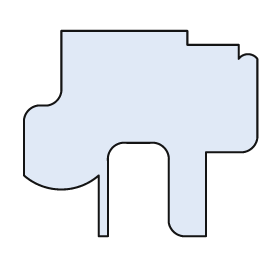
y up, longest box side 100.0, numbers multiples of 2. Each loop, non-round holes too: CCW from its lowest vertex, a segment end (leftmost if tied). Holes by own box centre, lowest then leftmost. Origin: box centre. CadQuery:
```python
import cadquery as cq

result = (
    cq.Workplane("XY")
    .moveTo(-18.0, -44.0)
    .lineTo(-14.0, -44.0)
    .lineTo(-14.0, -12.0)
    .threePointArc((-12.0, -6.0), (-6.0, -4.0))
    .lineTo(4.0, -4.0)
    .threePointArc((10.0, -6.0), (12.0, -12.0))
    .lineTo(12.0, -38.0)
    .threePointArc((14.0, -42.0), (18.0, -44.0))
    .lineTo(28.0, -44.0)
    .lineTo(28.0, -8.0)
    .lineTo(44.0, -8.0)
    .threePointArc((48.0, -6.0), (50.0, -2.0))
    .lineTo(50.0, 32.0)
    .threePointArc((46.0, 34.0), (42.0, 32.0))
    .lineTo(42.0, 38.0)
    .lineTo(20.0, 38.0)
    .lineTo(20.0, 44.0)
    .lineTo(-34.0, 44.0)
    .lineTo(-34.0, 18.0)
    .threePointArc((-36.0, 14.0), (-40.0, 12.0))
    .lineTo(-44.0, 12.0)
    .threePointArc((-48.0, 10.0), (-50.0, 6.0))
    .lineTo(-50.0, -18.0)
    .threePointArc((-34.0, -24.0), (-18.0, -18.0))
    .close()
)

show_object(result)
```